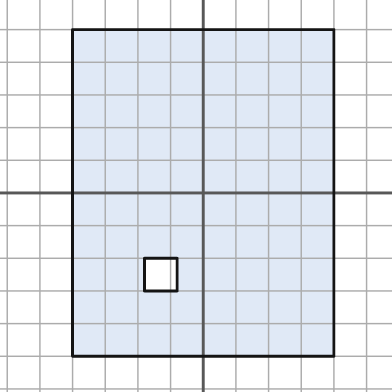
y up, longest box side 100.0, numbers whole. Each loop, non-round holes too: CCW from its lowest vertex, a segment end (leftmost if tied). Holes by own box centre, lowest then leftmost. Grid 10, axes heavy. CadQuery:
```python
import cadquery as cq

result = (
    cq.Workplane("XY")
    .moveTo(-40.0, -50.0)
    .lineTo(40.0, -50.0)
    .lineTo(40.0, 50.0)
    .lineTo(-40.0, 50.0)
    .close()
    .moveTo(-18.0, -30.0)
    .lineTo(-8.0, -30.0)
    .lineTo(-8.0, -20.0)
    .lineTo(-18.0, -20.0)
    .close()
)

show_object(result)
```